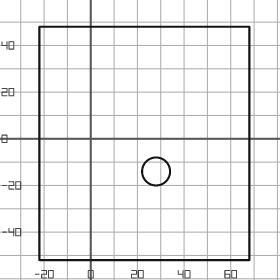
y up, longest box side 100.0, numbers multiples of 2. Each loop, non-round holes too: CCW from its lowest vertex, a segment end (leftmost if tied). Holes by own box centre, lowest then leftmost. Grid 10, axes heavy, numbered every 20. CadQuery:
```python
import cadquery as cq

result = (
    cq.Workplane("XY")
    .moveTo(-22.0, -52.0)
    .lineTo(68.0, -52.0)
    .lineTo(68.0, 48.0)
    .lineTo(-22.0, 48.0)
    .close()
    .moveTo(28.0, -14.0)
    .circle(6.0)
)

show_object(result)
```